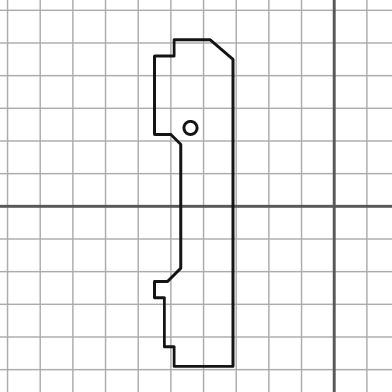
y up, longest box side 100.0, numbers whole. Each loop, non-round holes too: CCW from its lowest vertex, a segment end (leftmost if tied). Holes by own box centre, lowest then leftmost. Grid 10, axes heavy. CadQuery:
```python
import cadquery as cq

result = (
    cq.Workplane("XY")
    .moveTo(-49.0, -49.0)
    .lineTo(-31.0, -49.0)
    .lineTo(-31.0, 45.0)
    .lineTo(-38.0, 51.0)
    .lineTo(-49.0, 51.0)
    .lineTo(-49.0, 46.0)
    .lineTo(-55.0, 46.0)
    .lineTo(-55.0, 22.0)
    .lineTo(-50.0, 22.0)
    .lineTo(-47.0, 19.0)
    .lineTo(-47.0, -19.0)
    .lineTo(-51.0, -23.0)
    .lineTo(-55.0, -23.0)
    .lineTo(-55.0, -28.0)
    .lineTo(-52.0, -28.0)
    .lineTo(-52.0, -43.0)
    .lineTo(-49.0, -43.0)
    .close()
    .moveTo(-44.0, 24.0)
    .circle(2.0)
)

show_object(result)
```